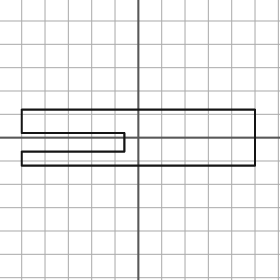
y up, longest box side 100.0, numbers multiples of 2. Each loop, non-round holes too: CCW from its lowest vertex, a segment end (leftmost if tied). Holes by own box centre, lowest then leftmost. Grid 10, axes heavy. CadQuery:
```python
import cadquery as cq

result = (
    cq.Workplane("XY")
    .moveTo(-50.0, -12.0)
    .lineTo(50.0, -12.0)
    .lineTo(50.0, 12.0)
    .lineTo(-50.0, 12.0)
    .lineTo(-50.0, 2.0)
    .lineTo(-6.0, 2.0)
    .lineTo(-6.0, -6.0)
    .lineTo(-50.0, -6.0)
    .close()
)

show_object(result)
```